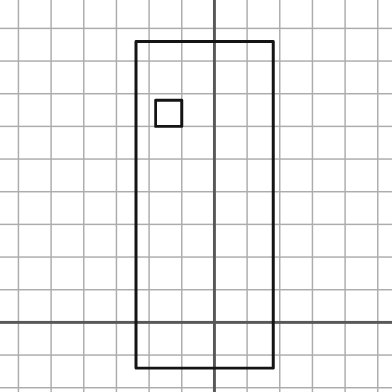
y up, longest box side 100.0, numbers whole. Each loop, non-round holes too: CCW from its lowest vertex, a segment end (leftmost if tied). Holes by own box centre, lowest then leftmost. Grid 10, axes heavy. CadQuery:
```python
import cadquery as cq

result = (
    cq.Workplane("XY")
    .moveTo(-24.0, -14.0)
    .lineTo(18.0, -14.0)
    .lineTo(18.0, 86.0)
    .lineTo(-24.0, 86.0)
    .close()
    .moveTo(-18.0, 60.0)
    .lineTo(-10.0, 60.0)
    .lineTo(-10.0, 68.0)
    .lineTo(-18.0, 68.0)
    .close()
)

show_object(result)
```